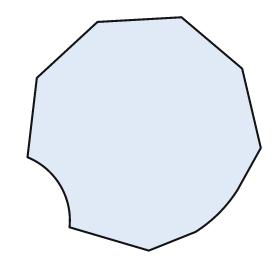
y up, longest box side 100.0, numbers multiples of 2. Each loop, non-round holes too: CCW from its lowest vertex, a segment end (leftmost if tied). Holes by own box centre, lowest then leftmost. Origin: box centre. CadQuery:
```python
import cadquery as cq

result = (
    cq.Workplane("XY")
    .moveTo(2.0, -50.0)
    .lineTo(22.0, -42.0)
    .threePointArc((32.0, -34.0), (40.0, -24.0))
    .lineTo(50.0, -6.0)
    .lineTo(42.0, 28.0)
    .lineTo(16.0, 50.0)
    .lineTo(-20.0, 48.0)
    .lineTo(-46.0, 24.0)
    .lineTo(-50.0, -10.0)
    .threePointArc((-36.0, -22.0), (-32.0, -40.0))
    .close()
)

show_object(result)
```